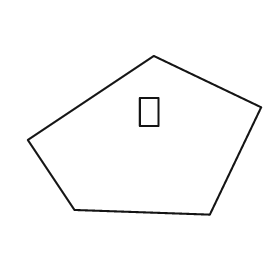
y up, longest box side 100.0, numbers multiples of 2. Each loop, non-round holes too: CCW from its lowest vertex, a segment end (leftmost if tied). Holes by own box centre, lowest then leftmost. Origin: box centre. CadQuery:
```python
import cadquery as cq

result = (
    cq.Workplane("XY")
    .moveTo(28.0, -34.0)
    .lineTo(50.0, 12.0)
    .lineTo(4.0, 34.0)
    .lineTo(-50.0, -2.0)
    .lineTo(-30.0, -32.0)
    .close()
    .moveTo(-2.0, 4.0)
    .lineTo(6.0, 4.0)
    .lineTo(6.0, 16.0)
    .lineTo(-2.0, 16.0)
    .close()
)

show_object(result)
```